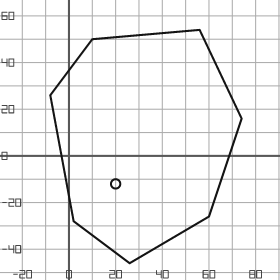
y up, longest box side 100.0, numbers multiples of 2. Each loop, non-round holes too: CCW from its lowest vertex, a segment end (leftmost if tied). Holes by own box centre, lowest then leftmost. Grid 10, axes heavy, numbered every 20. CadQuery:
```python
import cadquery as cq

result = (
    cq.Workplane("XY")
    .moveTo(26.0, -46.0)
    .lineTo(60.0, -26.0)
    .lineTo(74.0, 16.0)
    .lineTo(56.0, 54.0)
    .lineTo(10.0, 50.0)
    .lineTo(-8.0, 26.0)
    .lineTo(2.0, -28.0)
    .close()
    .moveTo(20.0, -12.0)
    .circle(2.0)
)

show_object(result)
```